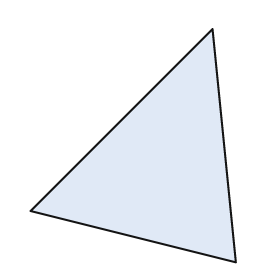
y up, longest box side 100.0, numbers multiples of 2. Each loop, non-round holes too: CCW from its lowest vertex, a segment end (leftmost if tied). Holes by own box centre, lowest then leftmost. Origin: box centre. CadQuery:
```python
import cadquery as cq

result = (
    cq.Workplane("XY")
    .moveTo(44.0, -50.0)
    .lineTo(34.0, 50.0)
    .lineTo(-44.0, -28.0)
    .close()
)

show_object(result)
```